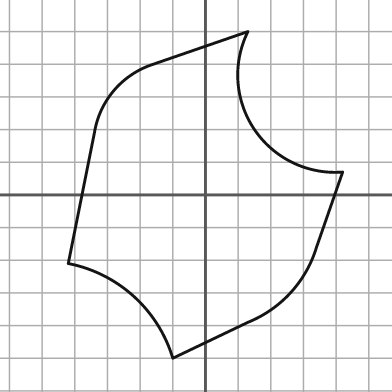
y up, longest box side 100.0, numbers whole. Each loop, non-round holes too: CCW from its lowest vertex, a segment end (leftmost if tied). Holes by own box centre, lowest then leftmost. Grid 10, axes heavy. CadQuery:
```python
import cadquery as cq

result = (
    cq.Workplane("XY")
    .moveTo(-10.0, -50.0)
    .lineTo(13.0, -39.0)
    .threePointArc((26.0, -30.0), (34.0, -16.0))
    .lineTo(42.0, 7.0)
    .threePointArc((15.0, 20.0), (13.0, 50.0))
    .lineTo(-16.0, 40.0)
    .threePointArc((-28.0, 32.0), (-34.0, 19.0))
    .lineTo(-42.0, -21.0)
    .threePointArc((-22.0, -31.0), (-10.0, -50.0))
    .close()
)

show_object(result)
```